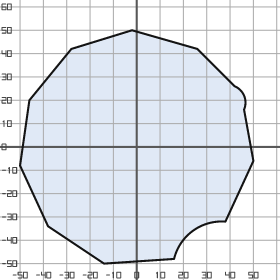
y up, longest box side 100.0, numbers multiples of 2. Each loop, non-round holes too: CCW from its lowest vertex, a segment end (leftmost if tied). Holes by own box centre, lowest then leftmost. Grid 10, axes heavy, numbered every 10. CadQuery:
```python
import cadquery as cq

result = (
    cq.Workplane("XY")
    .moveTo(-14.0, -50.0)
    .lineTo(16.0, -48.0)
    .threePointArc((24.0, -36.0), (38.0, -32.0))
    .lineTo(50.0, -6.0)
    .lineTo(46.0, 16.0)
    .threePointArc((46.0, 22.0), (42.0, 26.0))
    .lineTo(26.0, 42.0)
    .lineTo(-2.0, 50.0)
    .lineTo(-28.0, 42.0)
    .lineTo(-46.0, 20.0)
    .lineTo(-50.0, -8.0)
    .lineTo(-38.0, -34.0)
    .close()
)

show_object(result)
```